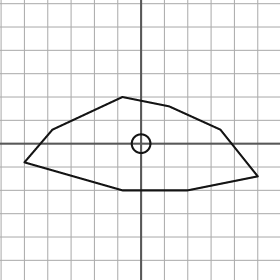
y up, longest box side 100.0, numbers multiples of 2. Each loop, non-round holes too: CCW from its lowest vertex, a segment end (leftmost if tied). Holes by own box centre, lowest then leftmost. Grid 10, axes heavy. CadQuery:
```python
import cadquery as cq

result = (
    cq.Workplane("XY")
    .moveTo(-8.0, -20.0)
    .lineTo(20.0, -20.0)
    .lineTo(50.0, -14.0)
    .lineTo(34.0, 6.0)
    .lineTo(12.0, 16.0)
    .lineTo(-8.0, 20.0)
    .lineTo(-38.0, 6.0)
    .lineTo(-50.0, -8.0)
    .close()
    .moveTo(0.0, 0.0)
    .circle(4.0)
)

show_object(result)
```